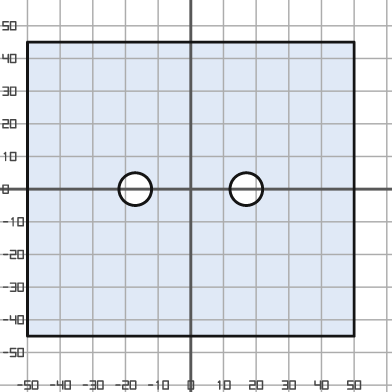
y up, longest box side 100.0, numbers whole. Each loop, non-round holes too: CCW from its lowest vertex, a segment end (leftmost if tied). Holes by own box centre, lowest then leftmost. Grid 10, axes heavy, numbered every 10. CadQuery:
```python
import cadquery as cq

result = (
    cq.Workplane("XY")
    .moveTo(-50.0, -45.0)
    .lineTo(50.0, -45.0)
    .lineTo(50.0, 45.0)
    .lineTo(-50.0, 45.0)
    .close()
    .moveTo(-17.0, 0.0)
    .circle(5.0)
    .moveTo(17.0, 0.0)
    .circle(5.0)
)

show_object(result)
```